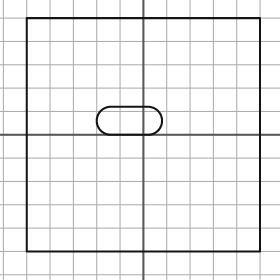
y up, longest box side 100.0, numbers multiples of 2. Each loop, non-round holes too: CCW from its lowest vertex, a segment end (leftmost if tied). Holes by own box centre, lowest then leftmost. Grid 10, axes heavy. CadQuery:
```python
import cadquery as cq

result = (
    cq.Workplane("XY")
    .moveTo(-50.0, -50.0)
    .lineTo(50.0, -50.0)
    .lineTo(50.0, 50.0)
    .lineTo(-50.0, 50.0)
    .close()
    .moveTo(-14.0, 0.0)
    .lineTo(2.0, 0.0)
    .threePointArc((8.0, 6.0), (2.0, 12.0))
    .lineTo(-14.0, 12.0)
    .threePointArc((-20.0, 6.0), (-14.0, 0.0))
    .close()
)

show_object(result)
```